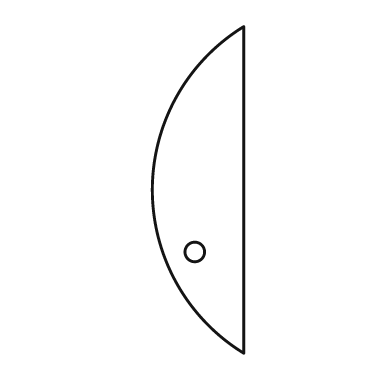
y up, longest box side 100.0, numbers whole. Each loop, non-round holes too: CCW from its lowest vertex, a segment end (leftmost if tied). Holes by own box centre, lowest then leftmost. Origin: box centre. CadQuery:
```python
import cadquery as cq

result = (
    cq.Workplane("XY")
    .moveTo(14.0, -50.0)
    .lineTo(14.0, 50.0)
    .threePointArc((-14.0, 0.0), (14.0, -50.0))
    .close()
    .moveTo(-1.0, -19.0)
    .circle(3.0)
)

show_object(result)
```